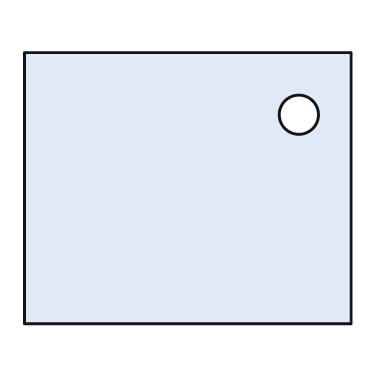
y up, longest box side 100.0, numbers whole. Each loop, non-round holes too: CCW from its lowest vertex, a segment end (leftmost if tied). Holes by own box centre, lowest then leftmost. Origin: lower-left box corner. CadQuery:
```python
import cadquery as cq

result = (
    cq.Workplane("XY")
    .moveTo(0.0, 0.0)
    .lineTo(100.0, 0.0)
    .lineTo(100.0, 83.0)
    .lineTo(0.0, 83.0)
    .close()
    .moveTo(84.0, 64.0)
    .circle(6.0)
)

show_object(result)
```